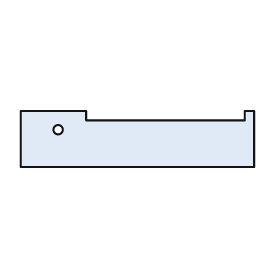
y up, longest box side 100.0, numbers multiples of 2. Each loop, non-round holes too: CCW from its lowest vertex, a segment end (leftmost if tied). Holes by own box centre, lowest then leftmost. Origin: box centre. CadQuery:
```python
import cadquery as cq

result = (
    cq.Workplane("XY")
    .moveTo(-50.0, -12.0)
    .lineTo(50.0, -12.0)
    .lineTo(50.0, 12.0)
    .lineTo(46.0, 12.0)
    .lineTo(46.0, 8.0)
    .lineTo(-22.0, 8.0)
    .lineTo(-22.0, 12.0)
    .lineTo(-50.0, 12.0)
    .close()
    .moveTo(-34.0, 4.0)
    .circle(2.0)
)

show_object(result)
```